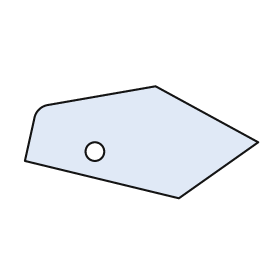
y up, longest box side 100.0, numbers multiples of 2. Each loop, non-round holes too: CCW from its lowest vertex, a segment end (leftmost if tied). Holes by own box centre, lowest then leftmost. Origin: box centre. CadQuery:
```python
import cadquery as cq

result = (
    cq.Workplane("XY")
    .moveTo(16.0, -24.0)
    .lineTo(50.0, 0.0)
    .lineTo(6.0, 24.0)
    .lineTo(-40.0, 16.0)
    .threePointArc((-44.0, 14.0), (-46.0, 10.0))
    .lineTo(-50.0, -8.0)
    .close()
    .moveTo(-20.0, -4.0)
    .circle(4.0)
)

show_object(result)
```